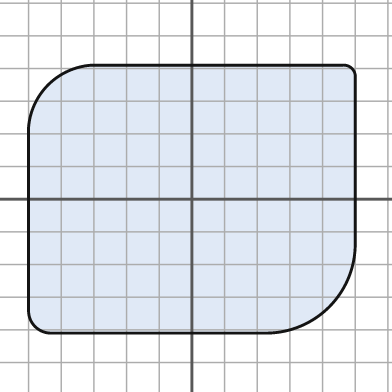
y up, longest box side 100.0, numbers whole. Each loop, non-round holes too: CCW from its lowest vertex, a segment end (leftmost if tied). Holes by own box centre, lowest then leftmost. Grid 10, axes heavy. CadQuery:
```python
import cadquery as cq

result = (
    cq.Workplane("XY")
    .moveTo(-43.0, -41.0)
    .lineTo(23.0, -41.0)
    .threePointArc((42.0, -33.0), (50.0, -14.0))
    .lineTo(50.0, 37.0)
    .threePointArc((49.0, 40.0), (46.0, 41.0))
    .lineTo(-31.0, 41.0)
    .threePointArc((-44.0, 35.0), (-50.0, 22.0))
    .lineTo(-50.0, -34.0)
    .threePointArc((-48.0, -39.0), (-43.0, -41.0))
    .close()
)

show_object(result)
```